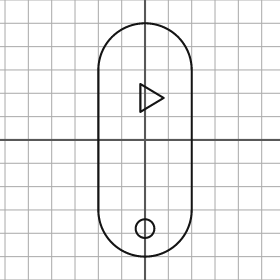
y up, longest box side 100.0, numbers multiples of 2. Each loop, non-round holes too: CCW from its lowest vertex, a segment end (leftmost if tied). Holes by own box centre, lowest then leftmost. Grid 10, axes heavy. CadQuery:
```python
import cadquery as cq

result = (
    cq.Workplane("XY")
    .moveTo(-20.0, -30.0)
    .threePointArc((0.0, -50.0), (20.0, -30.0))
    .lineTo(20.0, 30.0)
    .threePointArc((0.0, 50.0), (-20.0, 30.0))
    .close()
    .moveTo(0.0, -38.0)
    .circle(4.0)
    .moveTo(-2.0, 12.0)
    .lineTo(8.0, 18.0)
    .lineTo(-2.0, 24.0)
    .close()
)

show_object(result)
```